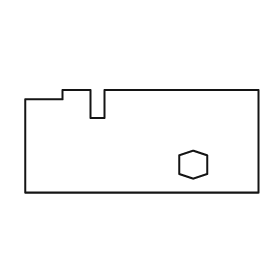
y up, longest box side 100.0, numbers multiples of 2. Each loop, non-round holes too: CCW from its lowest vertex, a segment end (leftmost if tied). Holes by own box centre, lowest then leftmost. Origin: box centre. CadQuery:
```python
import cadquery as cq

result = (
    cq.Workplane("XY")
    .moveTo(-50.0, -22.0)
    .lineTo(50.0, -22.0)
    .lineTo(50.0, 22.0)
    .lineTo(-16.0, 22.0)
    .lineTo(-16.0, 10.0)
    .lineTo(-22.0, 10.0)
    .lineTo(-22.0, 22.0)
    .lineTo(-34.0, 22.0)
    .lineTo(-34.0, 18.0)
    .lineTo(-50.0, 18.0)
    .close()
    .moveTo(22.0, -16.0)
    .lineTo(28.0, -14.0)
    .lineTo(28.0, -6.0)
    .lineTo(22.0, -4.0)
    .lineTo(16.0, -6.0)
    .lineTo(16.0, -14.0)
    .close()
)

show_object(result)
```